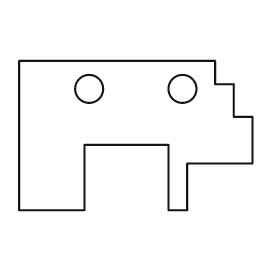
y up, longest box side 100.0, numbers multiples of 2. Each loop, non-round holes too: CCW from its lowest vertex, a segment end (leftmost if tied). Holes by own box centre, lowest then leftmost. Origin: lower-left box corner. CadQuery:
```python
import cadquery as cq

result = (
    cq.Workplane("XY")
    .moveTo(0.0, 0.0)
    .lineTo(28.0, 0.0)
    .lineTo(28.0, 28.0)
    .lineTo(64.0, 28.0)
    .lineTo(64.0, 0.0)
    .lineTo(72.0, 0.0)
    .lineTo(72.0, 20.0)
    .lineTo(100.0, 20.0)
    .lineTo(100.0, 40.0)
    .lineTo(92.0, 40.0)
    .lineTo(92.0, 54.0)
    .lineTo(84.0, 54.0)
    .lineTo(84.0, 64.0)
    .lineTo(0.0, 64.0)
    .close()
    .moveTo(30.0, 52.0)
    .circle(6.0)
    .moveTo(70.0, 52.0)
    .circle(6.0)
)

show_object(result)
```